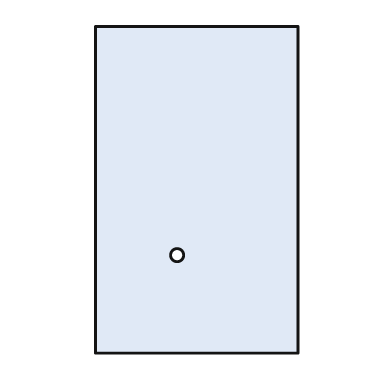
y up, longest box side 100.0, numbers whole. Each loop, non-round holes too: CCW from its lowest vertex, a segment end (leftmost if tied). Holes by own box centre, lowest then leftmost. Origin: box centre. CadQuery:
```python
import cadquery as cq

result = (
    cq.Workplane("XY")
    .moveTo(-31.0, -50.0)
    .lineTo(31.0, -50.0)
    .lineTo(31.0, 50.0)
    .lineTo(-31.0, 50.0)
    .close()
    .moveTo(-6.0, -20.0)
    .circle(2.0)
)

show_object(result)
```